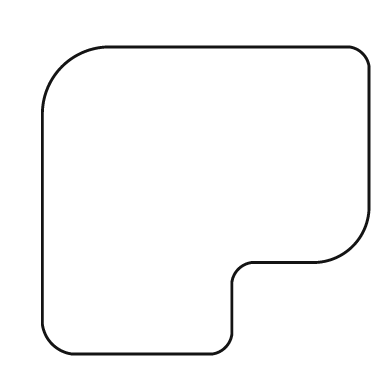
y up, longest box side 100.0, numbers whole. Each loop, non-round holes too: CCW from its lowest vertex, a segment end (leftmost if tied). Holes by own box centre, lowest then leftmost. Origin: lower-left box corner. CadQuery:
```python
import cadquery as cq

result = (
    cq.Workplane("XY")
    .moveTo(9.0, 0.0)
    .lineTo(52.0, 0.0)
    .threePointArc((56.0, 2.0), (58.0, 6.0))
    .lineTo(58.0, 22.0)
    .threePointArc((60.0, 26.0), (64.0, 28.0))
    .lineTo(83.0, 28.0)
    .threePointArc((95.0, 33.0), (100.0, 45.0))
    .lineTo(100.0, 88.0)
    .threePointArc((98.0, 92.0), (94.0, 94.0))
    .lineTo(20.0, 94.0)
    .threePointArc((6.0, 88.0), (0.0, 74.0))
    .lineTo(0.0, 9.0)
    .threePointArc((3.0, 3.0), (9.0, 0.0))
    .close()
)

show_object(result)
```